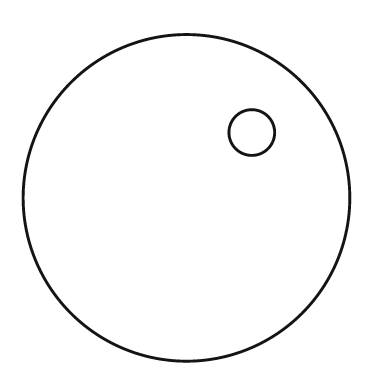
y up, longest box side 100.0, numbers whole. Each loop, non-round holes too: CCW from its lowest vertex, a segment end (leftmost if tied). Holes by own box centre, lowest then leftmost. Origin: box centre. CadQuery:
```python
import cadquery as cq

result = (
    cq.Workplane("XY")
    .moveTo(0.0, 0.0)
    .circle(50.0)
    .moveTo(20.0, 20.0)
    .circle(7.0)
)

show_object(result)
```